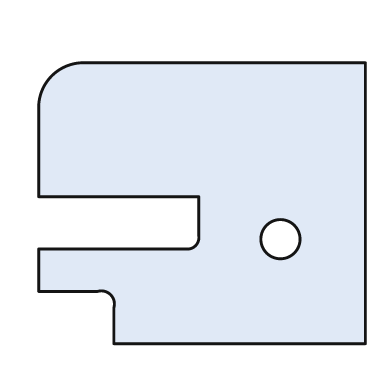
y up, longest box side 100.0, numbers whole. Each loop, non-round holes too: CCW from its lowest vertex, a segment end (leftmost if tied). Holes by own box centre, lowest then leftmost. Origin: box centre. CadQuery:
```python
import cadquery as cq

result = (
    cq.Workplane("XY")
    .moveTo(-27.0, -43.0)
    .lineTo(50.0, -43.0)
    .lineTo(50.0, 43.0)
    .lineTo(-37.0, 43.0)
    .threePointArc((-46.0, 39.0), (-50.0, 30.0))
    .lineTo(-50.0, 2.0)
    .lineTo(-1.0, 2.0)
    .lineTo(-1.0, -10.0)
    .threePointArc((-2.0, -13.0), (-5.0, -14.0))
    .lineTo(-50.0, -14.0)
    .lineTo(-50.0, -27.0)
    .lineTo(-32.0, -27.0)
    .threePointArc((-28.0, -28.0), (-27.0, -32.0))
    .close()
    .moveTo(24.0, -11.0)
    .circle(6.0)
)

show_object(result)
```